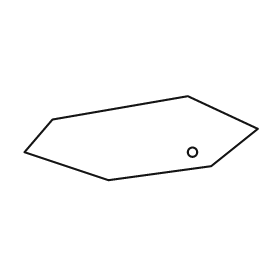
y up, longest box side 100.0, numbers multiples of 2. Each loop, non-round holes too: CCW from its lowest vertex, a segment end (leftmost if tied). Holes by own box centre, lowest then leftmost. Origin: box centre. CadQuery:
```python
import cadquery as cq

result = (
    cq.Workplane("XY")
    .moveTo(-14.0, -18.0)
    .lineTo(30.0, -12.0)
    .lineTo(50.0, 4.0)
    .lineTo(20.0, 18.0)
    .lineTo(-38.0, 8.0)
    .lineTo(-50.0, -6.0)
    .close()
    .moveTo(22.0, -6.0)
    .circle(2.0)
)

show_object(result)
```